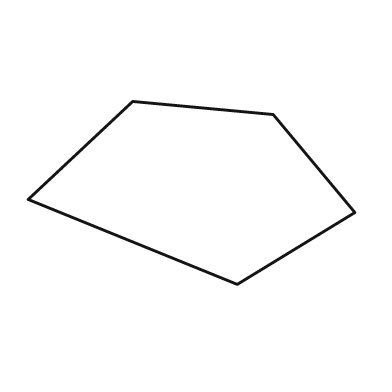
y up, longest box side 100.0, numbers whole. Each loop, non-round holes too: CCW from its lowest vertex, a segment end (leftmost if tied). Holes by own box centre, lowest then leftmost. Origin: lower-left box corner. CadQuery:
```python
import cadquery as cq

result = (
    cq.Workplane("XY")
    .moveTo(64.0, 0.0)
    .lineTo(100.0, 22.0)
    .lineTo(75.0, 52.0)
    .lineTo(32.0, 56.0)
    .lineTo(0.0, 26.0)
    .close()
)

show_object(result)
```